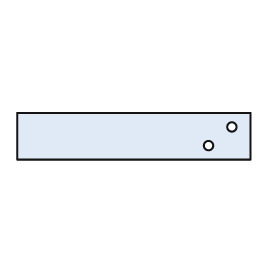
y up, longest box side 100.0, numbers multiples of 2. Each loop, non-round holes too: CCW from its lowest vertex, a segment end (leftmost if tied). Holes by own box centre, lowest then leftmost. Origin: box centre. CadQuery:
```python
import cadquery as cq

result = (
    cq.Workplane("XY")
    .moveTo(-50.0, -10.0)
    .lineTo(50.0, -10.0)
    .lineTo(50.0, 10.0)
    .lineTo(-50.0, 10.0)
    .close()
    .moveTo(32.0, -4.0)
    .circle(2.0)
    .moveTo(42.0, 4.0)
    .circle(2.0)
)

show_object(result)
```